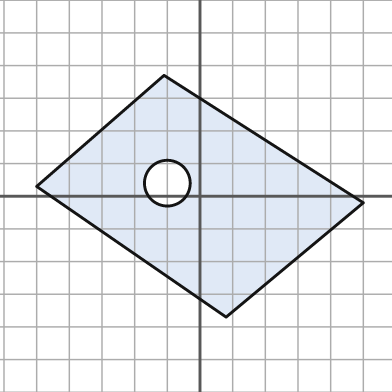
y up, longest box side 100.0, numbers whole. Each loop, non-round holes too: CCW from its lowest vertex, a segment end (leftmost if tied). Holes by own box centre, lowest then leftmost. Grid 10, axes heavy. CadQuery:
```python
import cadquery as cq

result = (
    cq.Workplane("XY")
    .moveTo(8.0, -37.0)
    .lineTo(50.0, -2.0)
    .lineTo(-11.0, 37.0)
    .lineTo(-50.0, 3.0)
    .close()
    .moveTo(-10.0, 4.0)
    .circle(7.0)
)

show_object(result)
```